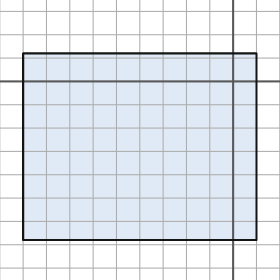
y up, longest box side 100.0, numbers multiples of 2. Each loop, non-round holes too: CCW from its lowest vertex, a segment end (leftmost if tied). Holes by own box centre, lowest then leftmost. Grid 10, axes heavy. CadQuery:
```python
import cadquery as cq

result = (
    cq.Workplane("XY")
    .moveTo(-90.0, -68.0)
    .lineTo(10.0, -68.0)
    .lineTo(10.0, 12.0)
    .lineTo(-90.0, 12.0)
    .close()
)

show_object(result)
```